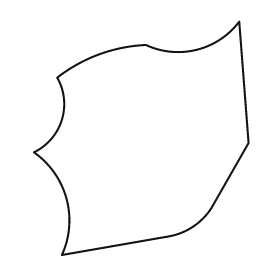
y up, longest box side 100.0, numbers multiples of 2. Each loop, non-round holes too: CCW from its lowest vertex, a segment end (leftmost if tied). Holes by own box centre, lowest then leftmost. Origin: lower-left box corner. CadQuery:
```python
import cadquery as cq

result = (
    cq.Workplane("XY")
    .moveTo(12.0, 0.0)
    .lineTo(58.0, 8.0)
    .threePointArc((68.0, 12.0), (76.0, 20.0))
    .lineTo(92.0, 48.0)
    .lineTo(88.0, 100.0)
    .threePointArc((70.0, 88.0), (48.0, 90.0))
    .threePointArc((28.0, 86.0), (10.0, 76.0))
    .threePointArc((12.0, 58.0), (0.0, 44.0))
    .threePointArc((14.0, 24.0), (12.0, 0.0))
    .close()
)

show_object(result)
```